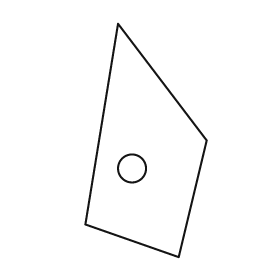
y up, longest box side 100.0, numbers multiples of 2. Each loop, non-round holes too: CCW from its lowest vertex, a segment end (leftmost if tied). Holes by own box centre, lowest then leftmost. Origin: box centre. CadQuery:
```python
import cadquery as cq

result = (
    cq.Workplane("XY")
    .moveTo(14.0, -50.0)
    .lineTo(26.0, 0.0)
    .lineTo(-12.0, 50.0)
    .lineTo(-26.0, -36.0)
    .close()
    .moveTo(-6.0, -12.0)
    .circle(6.0)
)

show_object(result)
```